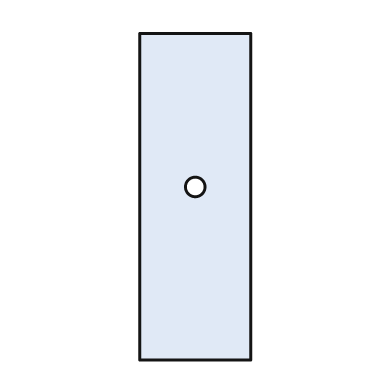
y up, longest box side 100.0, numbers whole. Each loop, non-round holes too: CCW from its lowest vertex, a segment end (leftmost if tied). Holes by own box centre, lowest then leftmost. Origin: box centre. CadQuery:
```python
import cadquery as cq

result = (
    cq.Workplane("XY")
    .moveTo(-17.0, -50.0)
    .lineTo(17.0, -50.0)
    .lineTo(17.0, 50.0)
    .lineTo(-17.0, 50.0)
    .close()
    .moveTo(0.0, 3.0)
    .circle(3.0)
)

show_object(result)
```